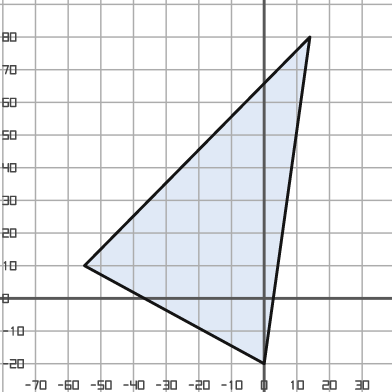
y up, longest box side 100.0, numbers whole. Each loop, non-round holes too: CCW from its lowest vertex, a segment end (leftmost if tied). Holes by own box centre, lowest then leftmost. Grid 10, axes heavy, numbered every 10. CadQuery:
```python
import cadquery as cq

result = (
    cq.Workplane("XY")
    .moveTo(0.0, -20.0)
    .lineTo(14.0, 80.0)
    .lineTo(-55.0, 10.0)
    .close()
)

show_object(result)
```